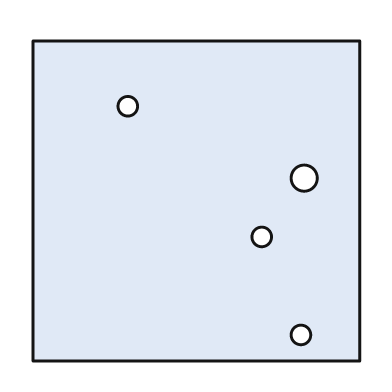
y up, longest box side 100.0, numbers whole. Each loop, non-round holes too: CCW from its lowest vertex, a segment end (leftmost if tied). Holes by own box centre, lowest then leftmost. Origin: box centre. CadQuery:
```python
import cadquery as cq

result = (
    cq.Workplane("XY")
    .moveTo(-50.0, -49.0)
    .lineTo(50.0, -49.0)
    .lineTo(50.0, 49.0)
    .lineTo(-50.0, 49.0)
    .close()
    .moveTo(32.0, -41.0)
    .circle(3.0)
    .moveTo(20.0, -11.0)
    .circle(3.0)
    .moveTo(33.0, 7.0)
    .circle(4.0)
    .moveTo(-21.0, 29.0)
    .circle(3.0)
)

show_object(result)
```